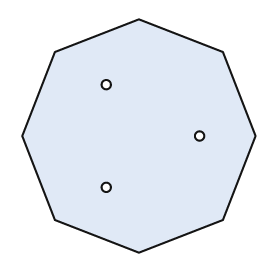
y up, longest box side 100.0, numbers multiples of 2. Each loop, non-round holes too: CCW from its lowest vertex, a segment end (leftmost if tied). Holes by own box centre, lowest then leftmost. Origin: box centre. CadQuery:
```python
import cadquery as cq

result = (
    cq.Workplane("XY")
    .moveTo(0.0, -50.0)
    .lineTo(36.0, -36.0)
    .lineTo(50.0, 0.0)
    .lineTo(36.0, 36.0)
    .lineTo(0.0, 50.0)
    .lineTo(-36.0, 36.0)
    .lineTo(-50.0, 0.0)
    .lineTo(-36.0, -36.0)
    .close()
    .moveTo(-14.0, -22.0)
    .circle(2.0)
    .moveTo(26.0, 0.0)
    .circle(2.0)
    .moveTo(-14.0, 22.0)
    .circle(2.0)
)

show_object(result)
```